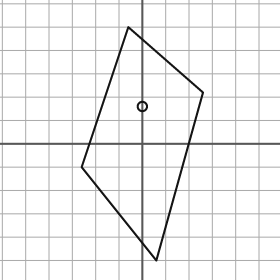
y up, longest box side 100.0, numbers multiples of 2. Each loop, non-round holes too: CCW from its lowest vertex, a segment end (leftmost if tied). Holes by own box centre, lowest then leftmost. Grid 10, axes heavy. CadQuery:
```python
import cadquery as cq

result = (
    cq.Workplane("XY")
    .moveTo(6.0, -50.0)
    .lineTo(26.0, 22.0)
    .lineTo(-6.0, 50.0)
    .lineTo(-26.0, -10.0)
    .close()
    .moveTo(0.0, 16.0)
    .circle(2.0)
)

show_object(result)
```